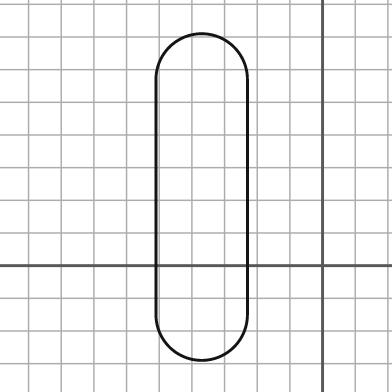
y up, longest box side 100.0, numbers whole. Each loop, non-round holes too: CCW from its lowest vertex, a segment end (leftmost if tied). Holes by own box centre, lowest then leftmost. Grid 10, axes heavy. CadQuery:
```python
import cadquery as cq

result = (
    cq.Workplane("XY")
    .moveTo(-51.0, -15.0)
    .threePointArc((-37.0, -29.0), (-23.0, -15.0))
    .lineTo(-23.0, 57.0)
    .threePointArc((-37.0, 71.0), (-51.0, 57.0))
    .close()
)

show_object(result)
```